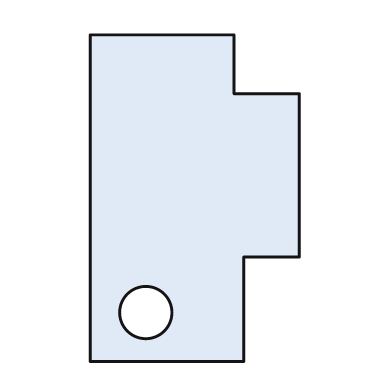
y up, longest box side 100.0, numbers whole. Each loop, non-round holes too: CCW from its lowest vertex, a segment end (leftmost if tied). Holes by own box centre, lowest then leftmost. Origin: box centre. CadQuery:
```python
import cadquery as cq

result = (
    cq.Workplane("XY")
    .moveTo(-32.0, -50.0)
    .lineTo(15.0, -50.0)
    .lineTo(15.0, -18.0)
    .lineTo(32.0, -18.0)
    .lineTo(32.0, 32.0)
    .lineTo(12.0, 32.0)
    .lineTo(12.0, 50.0)
    .lineTo(-32.0, 50.0)
    .close()
    .moveTo(-15.0, -35.0)
    .circle(8.0)
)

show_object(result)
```